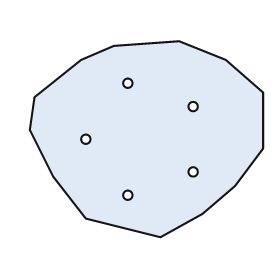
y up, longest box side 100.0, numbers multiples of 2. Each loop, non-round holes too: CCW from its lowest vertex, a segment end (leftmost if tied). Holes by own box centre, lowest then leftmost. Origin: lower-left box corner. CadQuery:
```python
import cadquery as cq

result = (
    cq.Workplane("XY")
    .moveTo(56.0, 0.0)
    .lineTo(74.0, 10.0)
    .lineTo(88.0, 22.0)
    .lineTo(100.0, 38.0)
    .lineTo(100.0, 62.0)
    .lineTo(84.0, 76.0)
    .lineTo(64.0, 84.0)
    .lineTo(36.0, 82.0)
    .lineTo(22.0, 76.0)
    .lineTo(2.0, 60.0)
    .lineTo(0.0, 46.0)
    .lineTo(10.0, 26.0)
    .lineTo(24.0, 8.0)
    .close()
    .moveTo(42.0, 18.0)
    .circle(2.0)
    .moveTo(70.0, 28.0)
    .circle(2.0)
    .moveTo(24.0, 42.0)
    .circle(2.0)
    .moveTo(70.0, 56.0)
    .circle(2.0)
    .moveTo(42.0, 66.0)
    .circle(2.0)
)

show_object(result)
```